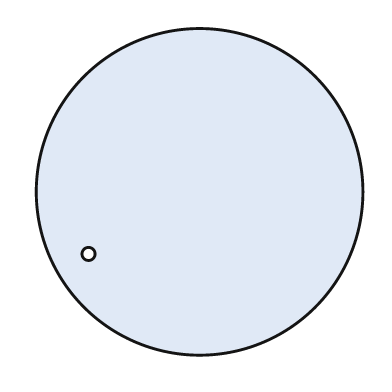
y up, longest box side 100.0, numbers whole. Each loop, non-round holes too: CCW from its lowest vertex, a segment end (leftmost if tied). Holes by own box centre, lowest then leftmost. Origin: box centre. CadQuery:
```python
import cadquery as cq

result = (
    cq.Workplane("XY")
    .moveTo(0.0, 0.0)
    .circle(50.0)
    .moveTo(-34.0, -19.0)
    .circle(2.0)
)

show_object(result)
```